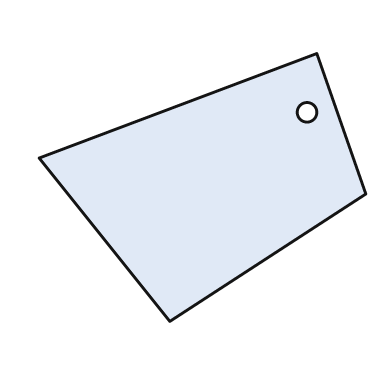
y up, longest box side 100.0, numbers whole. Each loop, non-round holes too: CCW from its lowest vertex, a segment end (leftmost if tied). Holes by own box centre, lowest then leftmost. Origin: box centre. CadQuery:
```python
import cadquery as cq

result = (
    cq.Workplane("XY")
    .moveTo(-10.0, -41.0)
    .lineTo(50.0, -2.0)
    .lineTo(35.0, 41.0)
    .lineTo(-50.0, 9.0)
    .close()
    .moveTo(32.0, 23.0)
    .circle(3.0)
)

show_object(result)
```